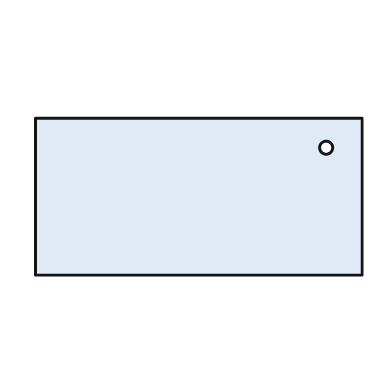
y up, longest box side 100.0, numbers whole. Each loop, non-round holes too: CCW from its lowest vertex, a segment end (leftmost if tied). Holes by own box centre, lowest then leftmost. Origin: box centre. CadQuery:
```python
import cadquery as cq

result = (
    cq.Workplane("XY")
    .moveTo(-50.0, -24.0)
    .lineTo(50.0, -24.0)
    .lineTo(50.0, 24.0)
    .lineTo(-50.0, 24.0)
    .close()
    .moveTo(39.0, 15.0)
    .circle(2.0)
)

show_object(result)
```